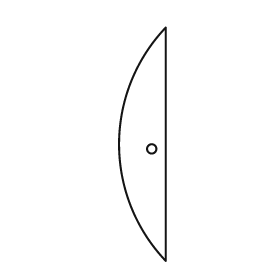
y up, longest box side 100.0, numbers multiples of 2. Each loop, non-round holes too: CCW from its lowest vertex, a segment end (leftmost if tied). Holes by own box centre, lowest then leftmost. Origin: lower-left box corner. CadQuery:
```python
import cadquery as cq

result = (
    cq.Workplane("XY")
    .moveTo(20.0, 0.0)
    .lineTo(20.0, 100.0)
    .threePointArc((0.0, 50.0), (20.0, 0.0))
    .close()
    .moveTo(14.0, 48.0)
    .circle(2.0)
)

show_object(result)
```